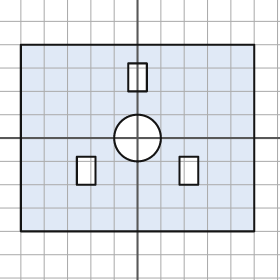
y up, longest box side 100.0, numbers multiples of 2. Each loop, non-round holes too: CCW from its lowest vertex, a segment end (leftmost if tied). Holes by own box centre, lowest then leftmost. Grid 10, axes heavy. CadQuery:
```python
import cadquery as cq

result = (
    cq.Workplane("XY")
    .moveTo(-50.0, -40.0)
    .lineTo(50.0, -40.0)
    .lineTo(50.0, 40.0)
    .lineTo(-50.0, 40.0)
    .close()
    .moveTo(-26.0, -20.0)
    .lineTo(-18.0, -20.0)
    .lineTo(-18.0, -8.0)
    .lineTo(-26.0, -8.0)
    .close()
    .moveTo(18.0, -20.0)
    .lineTo(26.0, -20.0)
    .lineTo(26.0, -8.0)
    .lineTo(18.0, -8.0)
    .close()
    .moveTo(0.0, 0.0)
    .circle(10.0)
    .moveTo(-4.0, 20.0)
    .lineTo(4.0, 20.0)
    .lineTo(4.0, 32.0)
    .lineTo(-4.0, 32.0)
    .close()
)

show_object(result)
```